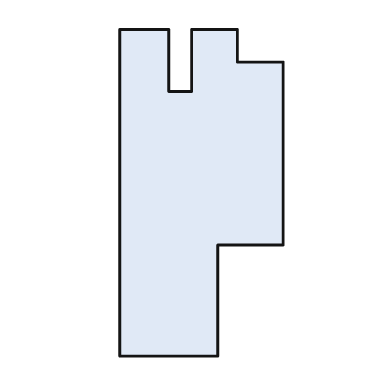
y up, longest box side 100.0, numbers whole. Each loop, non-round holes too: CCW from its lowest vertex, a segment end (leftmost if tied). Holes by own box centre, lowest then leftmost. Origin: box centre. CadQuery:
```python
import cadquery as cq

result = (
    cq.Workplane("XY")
    .moveTo(-25.0, -50.0)
    .lineTo(5.0, -50.0)
    .lineTo(5.0, -16.0)
    .lineTo(25.0, -16.0)
    .lineTo(25.0, 40.0)
    .lineTo(11.0, 40.0)
    .lineTo(11.0, 50.0)
    .lineTo(-3.0, 50.0)
    .lineTo(-3.0, 31.0)
    .lineTo(-10.0, 31.0)
    .lineTo(-10.0, 50.0)
    .lineTo(-25.0, 50.0)
    .close()
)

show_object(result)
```